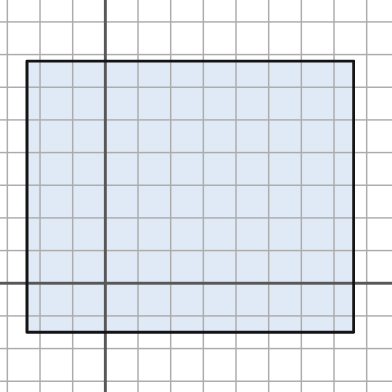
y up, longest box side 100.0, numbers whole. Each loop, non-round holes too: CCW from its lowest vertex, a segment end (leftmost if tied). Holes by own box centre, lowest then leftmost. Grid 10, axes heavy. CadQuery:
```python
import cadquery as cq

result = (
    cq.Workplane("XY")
    .moveTo(-24.0, -15.0)
    .lineTo(76.0, -15.0)
    .lineTo(76.0, 68.0)
    .lineTo(-24.0, 68.0)
    .close()
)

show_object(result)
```